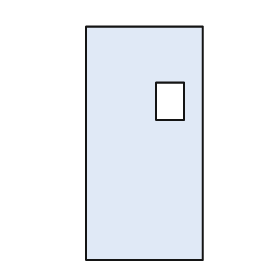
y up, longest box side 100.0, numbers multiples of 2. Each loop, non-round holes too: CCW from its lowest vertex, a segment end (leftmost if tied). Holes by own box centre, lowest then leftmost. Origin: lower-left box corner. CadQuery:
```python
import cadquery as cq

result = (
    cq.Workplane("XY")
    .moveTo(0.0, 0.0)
    .lineTo(50.0, 0.0)
    .lineTo(50.0, 100.0)
    .lineTo(0.0, 100.0)
    .close()
    .moveTo(30.0, 60.0)
    .lineTo(42.0, 60.0)
    .lineTo(42.0, 76.0)
    .lineTo(30.0, 76.0)
    .close()
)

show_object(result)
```